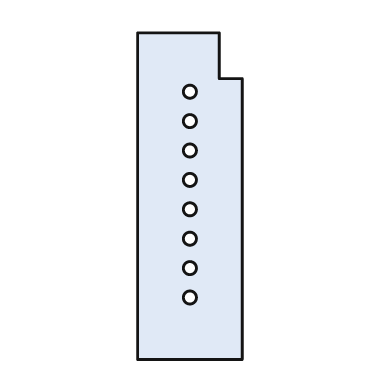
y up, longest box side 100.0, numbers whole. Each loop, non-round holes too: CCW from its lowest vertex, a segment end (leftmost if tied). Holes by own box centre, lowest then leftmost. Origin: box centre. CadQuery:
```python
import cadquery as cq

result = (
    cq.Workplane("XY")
    .moveTo(-16.0, -50.0)
    .lineTo(16.0, -50.0)
    .lineTo(16.0, 36.0)
    .lineTo(9.0, 36.0)
    .lineTo(9.0, 50.0)
    .lineTo(-16.0, 50.0)
    .close()
    .moveTo(0.0, -31.0)
    .circle(2.0)
    .moveTo(0.0, -22.0)
    .circle(2.0)
    .moveTo(0.0, -13.0)
    .circle(2.0)
    .moveTo(0.0, -4.0)
    .circle(2.0)
    .moveTo(0.0, 5.0)
    .circle(2.0)
    .moveTo(0.0, 14.0)
    .circle(2.0)
    .moveTo(0.0, 23.0)
    .circle(2.0)
    .moveTo(0.0, 32.0)
    .circle(2.0)
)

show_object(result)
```